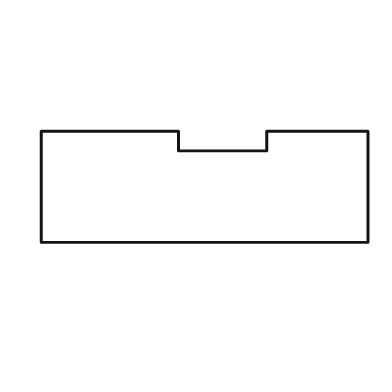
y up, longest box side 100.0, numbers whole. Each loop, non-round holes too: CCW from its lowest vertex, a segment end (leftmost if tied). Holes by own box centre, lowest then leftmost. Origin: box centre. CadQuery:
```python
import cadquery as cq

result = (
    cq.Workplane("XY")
    .moveTo(-50.0, -17.0)
    .lineTo(50.0, -17.0)
    .lineTo(50.0, 17.0)
    .lineTo(19.0, 17.0)
    .lineTo(19.0, 11.0)
    .lineTo(-8.0, 11.0)
    .lineTo(-8.0, 17.0)
    .lineTo(-50.0, 17.0)
    .close()
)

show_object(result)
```